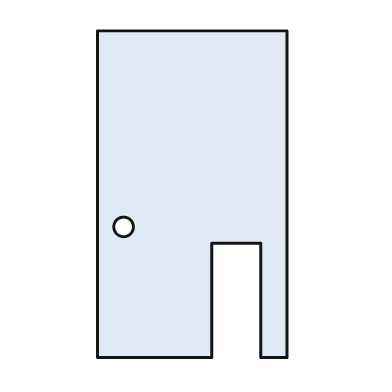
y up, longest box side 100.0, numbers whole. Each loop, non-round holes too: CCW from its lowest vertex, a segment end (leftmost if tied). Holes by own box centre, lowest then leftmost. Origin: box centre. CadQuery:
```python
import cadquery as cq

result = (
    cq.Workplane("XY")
    .moveTo(-29.0, -50.0)
    .lineTo(6.0, -50.0)
    .lineTo(6.0, -15.0)
    .lineTo(21.0, -15.0)
    .lineTo(21.0, -50.0)
    .lineTo(29.0, -50.0)
    .lineTo(29.0, 50.0)
    .lineTo(-29.0, 50.0)
    .close()
    .moveTo(-21.0, -10.0)
    .circle(3.0)
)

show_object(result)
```